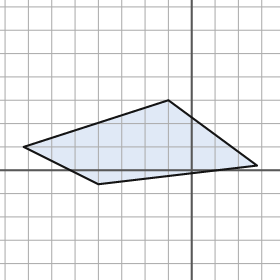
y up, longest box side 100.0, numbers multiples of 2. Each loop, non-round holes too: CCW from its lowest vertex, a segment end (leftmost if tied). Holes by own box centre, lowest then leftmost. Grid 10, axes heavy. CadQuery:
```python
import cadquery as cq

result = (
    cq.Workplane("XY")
    .moveTo(-40.0, -6.0)
    .lineTo(28.0, 2.0)
    .lineTo(-10.0, 30.0)
    .lineTo(-72.0, 10.0)
    .close()
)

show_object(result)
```